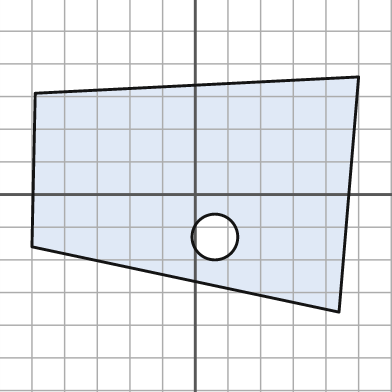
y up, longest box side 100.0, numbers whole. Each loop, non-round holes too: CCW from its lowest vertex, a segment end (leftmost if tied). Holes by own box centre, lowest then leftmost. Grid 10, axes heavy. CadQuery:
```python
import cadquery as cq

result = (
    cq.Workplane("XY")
    .moveTo(44.0, -36.0)
    .lineTo(50.0, 36.0)
    .lineTo(-49.0, 31.0)
    .lineTo(-50.0, -16.0)
    .close()
    .moveTo(6.0, -13.0)
    .circle(7.0)
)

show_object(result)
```